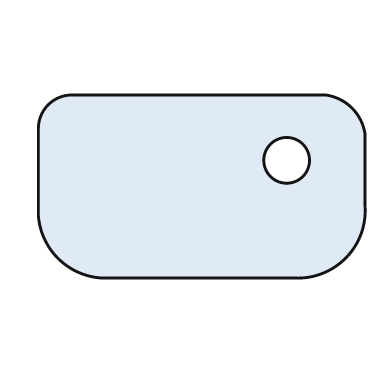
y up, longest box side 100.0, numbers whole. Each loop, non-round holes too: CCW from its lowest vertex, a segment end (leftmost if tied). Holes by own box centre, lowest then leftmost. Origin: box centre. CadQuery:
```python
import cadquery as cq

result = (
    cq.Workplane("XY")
    .moveTo(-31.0, -28.0)
    .lineTo(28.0, -28.0)
    .threePointArc((44.0, -22.0), (50.0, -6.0))
    .lineTo(50.0, 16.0)
    .threePointArc((46.0, 24.0), (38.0, 28.0))
    .lineTo(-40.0, 28.0)
    .threePointArc((-47.0, 25.0), (-50.0, 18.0))
    .lineTo(-50.0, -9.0)
    .threePointArc((-44.0, -22.0), (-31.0, -28.0))
    .close()
    .moveTo(26.0, 8.0)
    .circle(7.0)
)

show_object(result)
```